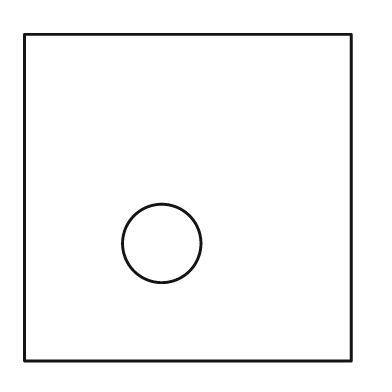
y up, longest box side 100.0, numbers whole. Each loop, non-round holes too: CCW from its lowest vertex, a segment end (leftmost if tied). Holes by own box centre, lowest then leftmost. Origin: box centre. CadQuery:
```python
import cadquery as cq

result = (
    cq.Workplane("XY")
    .moveTo(-50.0, -50.0)
    .lineTo(50.0, -50.0)
    .lineTo(50.0, 50.0)
    .lineTo(-50.0, 50.0)
    .close()
    .moveTo(-8.0, -14.0)
    .circle(12.0)
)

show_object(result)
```